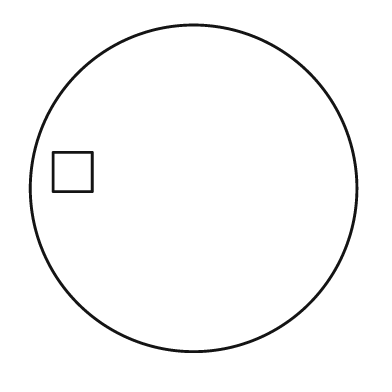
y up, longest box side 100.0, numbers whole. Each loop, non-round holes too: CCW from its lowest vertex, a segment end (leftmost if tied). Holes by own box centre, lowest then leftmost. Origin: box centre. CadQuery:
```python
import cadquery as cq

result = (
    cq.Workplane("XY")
    .moveTo(0.0, 0.0)
    .circle(50.0)
    .moveTo(-43.0, -1.0)
    .lineTo(-31.0, -1.0)
    .lineTo(-31.0, 11.0)
    .lineTo(-43.0, 11.0)
    .close()
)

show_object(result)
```